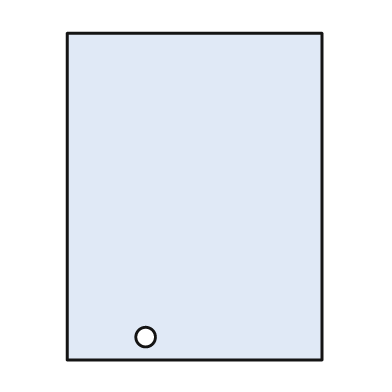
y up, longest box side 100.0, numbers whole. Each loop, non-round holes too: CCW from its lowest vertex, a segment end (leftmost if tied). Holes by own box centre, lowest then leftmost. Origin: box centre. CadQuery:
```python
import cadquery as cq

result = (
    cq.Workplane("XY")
    .moveTo(-39.0, -50.0)
    .lineTo(39.0, -50.0)
    .lineTo(39.0, 50.0)
    .lineTo(-39.0, 50.0)
    .close()
    .moveTo(-15.0, -43.0)
    .circle(3.0)
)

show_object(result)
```